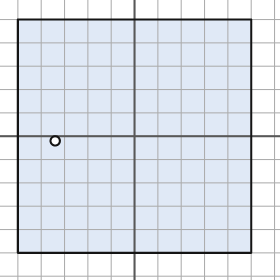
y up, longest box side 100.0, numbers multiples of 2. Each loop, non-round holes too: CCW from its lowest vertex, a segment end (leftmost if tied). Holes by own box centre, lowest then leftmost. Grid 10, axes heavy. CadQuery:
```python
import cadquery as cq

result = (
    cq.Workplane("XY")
    .moveTo(-50.0, -50.0)
    .lineTo(50.0, -50.0)
    .lineTo(50.0, 50.0)
    .lineTo(-50.0, 50.0)
    .close()
    .moveTo(-34.0, -2.0)
    .circle(2.0)
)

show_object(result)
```